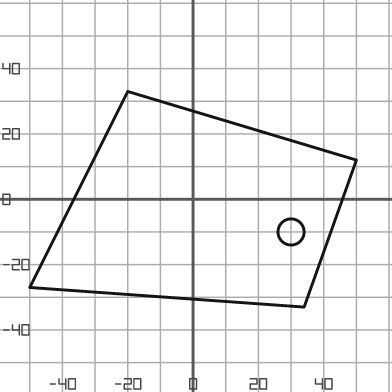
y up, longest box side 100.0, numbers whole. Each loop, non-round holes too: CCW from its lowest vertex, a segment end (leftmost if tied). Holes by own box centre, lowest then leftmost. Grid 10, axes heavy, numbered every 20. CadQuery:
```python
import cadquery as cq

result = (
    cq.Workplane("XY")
    .moveTo(34.0, -33.0)
    .lineTo(50.0, 12.0)
    .lineTo(-20.0, 33.0)
    .lineTo(-50.0, -27.0)
    .close()
    .moveTo(30.0, -10.0)
    .circle(4.0)
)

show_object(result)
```